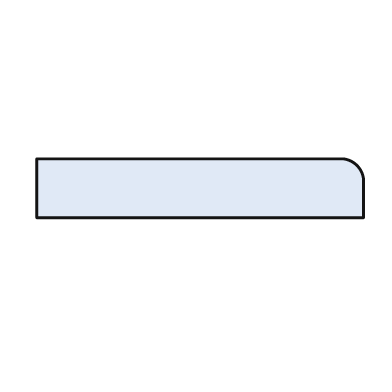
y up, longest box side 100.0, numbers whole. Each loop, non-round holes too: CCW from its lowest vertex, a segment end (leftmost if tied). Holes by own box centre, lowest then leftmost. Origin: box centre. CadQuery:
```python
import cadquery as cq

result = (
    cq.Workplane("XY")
    .moveTo(-50.0, -9.0)
    .lineTo(50.0, -9.0)
    .lineTo(50.0, 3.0)
    .threePointArc((48.0, 7.0), (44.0, 9.0))
    .lineTo(-50.0, 9.0)
    .close()
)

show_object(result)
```